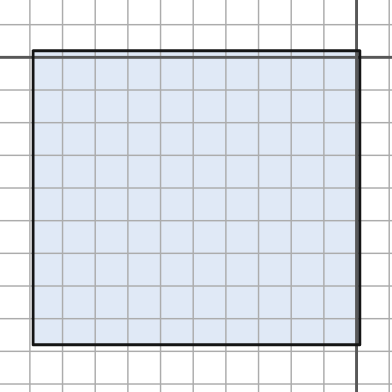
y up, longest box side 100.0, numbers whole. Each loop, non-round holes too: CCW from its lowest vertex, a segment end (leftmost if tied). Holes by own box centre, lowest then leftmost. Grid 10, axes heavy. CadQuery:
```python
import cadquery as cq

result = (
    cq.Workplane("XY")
    .moveTo(-99.0, -88.0)
    .lineTo(1.0, -88.0)
    .lineTo(1.0, 2.0)
    .lineTo(-99.0, 2.0)
    .close()
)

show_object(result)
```